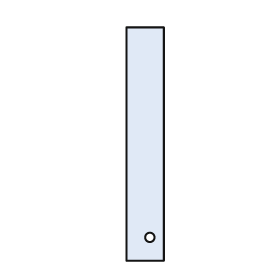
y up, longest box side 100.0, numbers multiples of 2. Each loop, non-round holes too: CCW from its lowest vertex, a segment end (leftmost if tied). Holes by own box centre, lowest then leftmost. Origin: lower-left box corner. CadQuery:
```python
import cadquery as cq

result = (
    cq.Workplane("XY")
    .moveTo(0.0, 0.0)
    .lineTo(16.0, 0.0)
    .lineTo(16.0, 100.0)
    .lineTo(0.0, 100.0)
    .close()
    .moveTo(10.0, 10.0)
    .circle(2.0)
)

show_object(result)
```